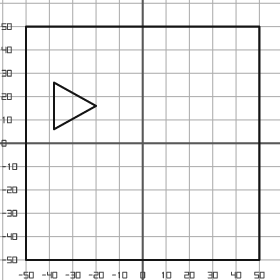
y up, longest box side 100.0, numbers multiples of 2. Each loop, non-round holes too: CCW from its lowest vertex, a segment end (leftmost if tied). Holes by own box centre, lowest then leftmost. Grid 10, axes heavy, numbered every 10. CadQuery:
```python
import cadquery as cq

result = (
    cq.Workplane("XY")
    .moveTo(-50.0, -50.0)
    .lineTo(50.0, -50.0)
    .lineTo(50.0, 50.0)
    .lineTo(-50.0, 50.0)
    .close()
    .moveTo(-38.0, 6.0)
    .lineTo(-20.0, 16.0)
    .lineTo(-38.0, 26.0)
    .close()
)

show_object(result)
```